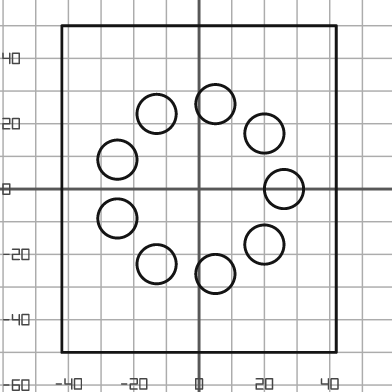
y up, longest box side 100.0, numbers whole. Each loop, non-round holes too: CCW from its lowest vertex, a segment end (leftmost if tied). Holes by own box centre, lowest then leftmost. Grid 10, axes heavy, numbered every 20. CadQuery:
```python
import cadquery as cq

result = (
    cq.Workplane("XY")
    .moveTo(-42.0, -50.0)
    .lineTo(42.0, -50.0)
    .lineTo(42.0, 50.0)
    .lineTo(-42.0, 50.0)
    .close()
    .moveTo(5.0, -26.0)
    .circle(6.0)
    .moveTo(-13.0, -23.0)
    .circle(6.0)
    .moveTo(20.0, -17.0)
    .circle(6.0)
    .moveTo(-25.0, -9.0)
    .circle(6.0)
    .moveTo(26.0, 0.0)
    .circle(6.0)
    .moveTo(-25.0, 9.0)
    .circle(6.0)
    .moveTo(20.0, 17.0)
    .circle(6.0)
    .moveTo(-13.0, 23.0)
    .circle(6.0)
    .moveTo(5.0, 26.0)
    .circle(6.0)
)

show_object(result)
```